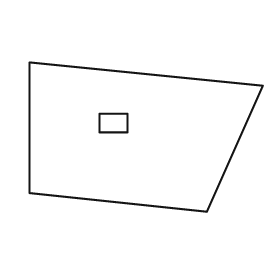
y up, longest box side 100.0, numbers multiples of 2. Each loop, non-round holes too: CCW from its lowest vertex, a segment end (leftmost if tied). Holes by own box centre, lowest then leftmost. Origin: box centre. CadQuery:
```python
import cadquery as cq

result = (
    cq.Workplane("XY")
    .moveTo(26.0, -32.0)
    .lineTo(50.0, 22.0)
    .lineTo(-50.0, 32.0)
    .lineTo(-50.0, -24.0)
    .close()
    .moveTo(-20.0, 2.0)
    .lineTo(-8.0, 2.0)
    .lineTo(-8.0, 10.0)
    .lineTo(-20.0, 10.0)
    .close()
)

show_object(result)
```